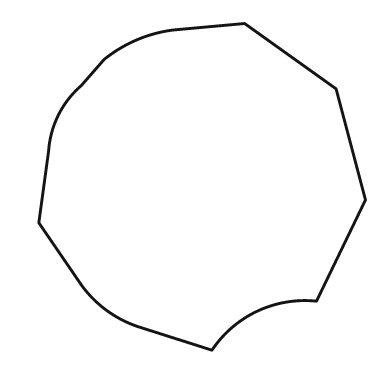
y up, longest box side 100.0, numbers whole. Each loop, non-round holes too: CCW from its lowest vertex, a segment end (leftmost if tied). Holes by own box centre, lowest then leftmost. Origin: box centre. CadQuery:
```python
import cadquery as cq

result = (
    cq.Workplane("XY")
    .moveTo(3.0, -50.0)
    .threePointArc((17.0, -38.0), (35.0, -35.0))
    .lineTo(50.0, -4.0)
    .lineTo(41.0, 30.0)
    .lineTo(13.0, 50.0)
    .lineTo(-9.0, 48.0)
    .threePointArc((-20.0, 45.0), (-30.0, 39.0))
    .lineTo(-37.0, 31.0)
    .threePointArc((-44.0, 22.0), (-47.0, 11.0))
    .lineTo(-50.0, -11.0)
    .lineTo(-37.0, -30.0)
    .threePointArc((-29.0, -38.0), (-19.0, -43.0))
    .close()
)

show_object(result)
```